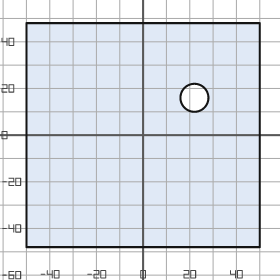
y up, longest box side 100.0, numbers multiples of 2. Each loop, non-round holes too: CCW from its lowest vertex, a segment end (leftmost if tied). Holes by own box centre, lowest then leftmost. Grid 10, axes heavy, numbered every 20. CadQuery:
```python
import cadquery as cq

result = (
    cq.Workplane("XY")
    .moveTo(-50.0, -48.0)
    .lineTo(50.0, -48.0)
    .lineTo(50.0, 48.0)
    .lineTo(-50.0, 48.0)
    .close()
    .moveTo(22.0, 16.0)
    .circle(6.0)
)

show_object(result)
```